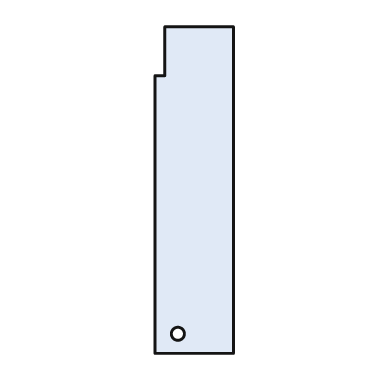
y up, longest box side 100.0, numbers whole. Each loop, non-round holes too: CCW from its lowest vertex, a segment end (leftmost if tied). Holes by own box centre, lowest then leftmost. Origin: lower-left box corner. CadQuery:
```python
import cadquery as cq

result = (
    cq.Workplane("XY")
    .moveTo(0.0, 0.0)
    .lineTo(24.0, 0.0)
    .lineTo(24.0, 100.0)
    .lineTo(3.0, 100.0)
    .lineTo(3.0, 85.0)
    .lineTo(0.0, 85.0)
    .close()
    .moveTo(7.0, 6.0)
    .circle(2.0)
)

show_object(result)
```